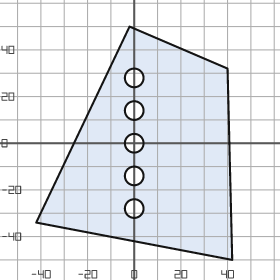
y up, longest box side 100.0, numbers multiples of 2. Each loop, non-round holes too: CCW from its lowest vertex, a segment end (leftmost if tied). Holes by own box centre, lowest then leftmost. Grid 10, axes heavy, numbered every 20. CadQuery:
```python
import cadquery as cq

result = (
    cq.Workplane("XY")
    .moveTo(42.0, -50.0)
    .lineTo(40.0, 32.0)
    .lineTo(-2.0, 50.0)
    .lineTo(-42.0, -34.0)
    .close()
    .moveTo(0.0, -28.0)
    .circle(4.0)
    .moveTo(0.0, -14.0)
    .circle(4.0)
    .moveTo(0.0, 0.0)
    .circle(4.0)
    .moveTo(0.0, 14.0)
    .circle(4.0)
    .moveTo(0.0, 28.0)
    .circle(4.0)
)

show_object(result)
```